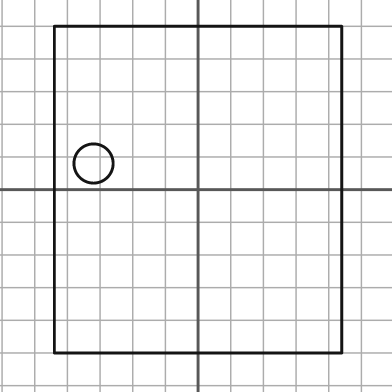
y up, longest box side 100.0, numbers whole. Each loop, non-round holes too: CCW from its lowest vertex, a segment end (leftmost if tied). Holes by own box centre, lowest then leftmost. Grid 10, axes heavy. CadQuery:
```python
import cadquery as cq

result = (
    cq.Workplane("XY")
    .moveTo(-44.0, -50.0)
    .lineTo(44.0, -50.0)
    .lineTo(44.0, 50.0)
    .lineTo(-44.0, 50.0)
    .close()
    .moveTo(-32.0, 8.0)
    .circle(6.0)
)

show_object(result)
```